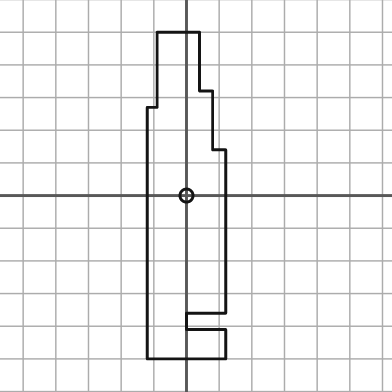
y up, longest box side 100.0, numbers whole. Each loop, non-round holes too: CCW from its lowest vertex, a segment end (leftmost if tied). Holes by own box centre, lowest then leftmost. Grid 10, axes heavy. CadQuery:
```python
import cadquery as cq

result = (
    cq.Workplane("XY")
    .moveTo(-12.0, -50.0)
    .lineTo(12.0, -50.0)
    .lineTo(12.0, -41.0)
    .lineTo(0.0, -41.0)
    .lineTo(0.0, -36.0)
    .lineTo(12.0, -36.0)
    .lineTo(12.0, 14.0)
    .lineTo(8.0, 14.0)
    .lineTo(8.0, 32.0)
    .lineTo(4.0, 32.0)
    .lineTo(4.0, 50.0)
    .lineTo(-9.0, 50.0)
    .lineTo(-9.0, 27.0)
    .lineTo(-12.0, 27.0)
    .close()
    .moveTo(0.0, 0.0)
    .circle(2.0)
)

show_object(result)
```